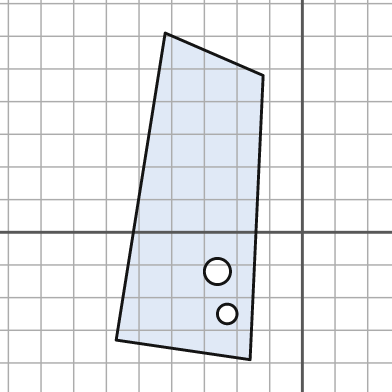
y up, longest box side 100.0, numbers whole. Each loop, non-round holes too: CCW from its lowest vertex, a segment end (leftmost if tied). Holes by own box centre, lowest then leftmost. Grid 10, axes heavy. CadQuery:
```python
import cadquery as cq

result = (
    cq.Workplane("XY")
    .moveTo(-16.0, -39.0)
    .lineTo(-12.0, 48.0)
    .lineTo(-42.0, 61.0)
    .lineTo(-57.0, -33.0)
    .close()
    .moveTo(-23.0, -25.0)
    .circle(3.0)
    .moveTo(-26.0, -12.0)
    .circle(4.0)
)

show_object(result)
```